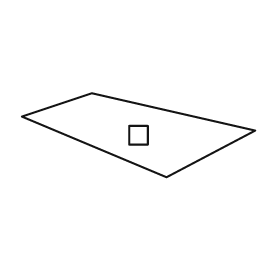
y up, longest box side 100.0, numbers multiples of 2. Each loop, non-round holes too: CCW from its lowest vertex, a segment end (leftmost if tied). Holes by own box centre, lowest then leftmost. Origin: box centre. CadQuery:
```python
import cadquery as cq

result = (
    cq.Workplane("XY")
    .moveTo(12.0, -18.0)
    .lineTo(50.0, 2.0)
    .lineTo(-20.0, 18.0)
    .lineTo(-50.0, 8.0)
    .close()
    .moveTo(-4.0, -4.0)
    .lineTo(4.0, -4.0)
    .lineTo(4.0, 4.0)
    .lineTo(-4.0, 4.0)
    .close()
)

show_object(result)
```